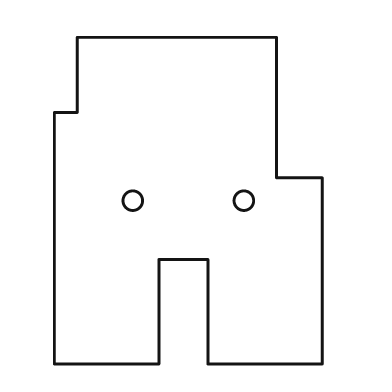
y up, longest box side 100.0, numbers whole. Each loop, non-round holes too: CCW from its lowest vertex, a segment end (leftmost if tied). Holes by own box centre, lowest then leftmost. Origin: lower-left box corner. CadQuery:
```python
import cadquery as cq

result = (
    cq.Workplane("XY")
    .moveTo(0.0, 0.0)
    .lineTo(32.0, 0.0)
    .lineTo(32.0, 32.0)
    .lineTo(47.0, 32.0)
    .lineTo(47.0, 0.0)
    .lineTo(82.0, 0.0)
    .lineTo(82.0, 57.0)
    .lineTo(68.0, 57.0)
    .lineTo(68.0, 100.0)
    .lineTo(7.0, 100.0)
    .lineTo(7.0, 77.0)
    .lineTo(0.0, 77.0)
    .close()
    .moveTo(24.0, 50.0)
    .circle(3.0)
    .moveTo(58.0, 50.0)
    .circle(3.0)
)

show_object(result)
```